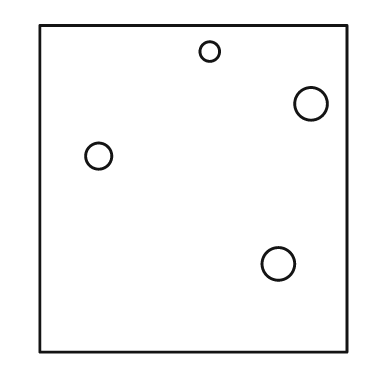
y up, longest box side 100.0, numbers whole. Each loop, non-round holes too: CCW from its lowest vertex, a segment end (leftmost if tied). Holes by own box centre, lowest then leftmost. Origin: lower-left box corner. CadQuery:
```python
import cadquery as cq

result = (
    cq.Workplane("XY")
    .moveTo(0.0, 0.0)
    .lineTo(94.0, 0.0)
    .lineTo(94.0, 100.0)
    .lineTo(0.0, 100.0)
    .close()
    .moveTo(73.0, 27.0)
    .circle(5.0)
    .moveTo(18.0, 60.0)
    .circle(4.0)
    .moveTo(83.0, 76.0)
    .circle(5.0)
    .moveTo(52.0, 92.0)
    .circle(3.0)
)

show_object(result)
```